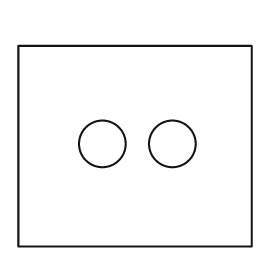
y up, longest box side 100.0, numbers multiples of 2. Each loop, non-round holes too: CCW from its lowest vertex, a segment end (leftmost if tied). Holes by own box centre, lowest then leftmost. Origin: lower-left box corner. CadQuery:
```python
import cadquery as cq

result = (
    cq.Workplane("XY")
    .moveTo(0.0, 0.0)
    .lineTo(100.0, 0.0)
    .lineTo(100.0, 86.0)
    .lineTo(0.0, 86.0)
    .close()
    .moveTo(36.0, 44.0)
    .circle(10.0)
    .moveTo(66.0, 44.0)
    .circle(10.0)
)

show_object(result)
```